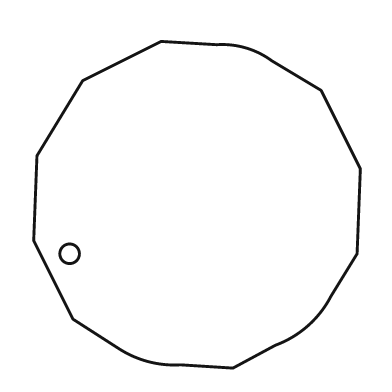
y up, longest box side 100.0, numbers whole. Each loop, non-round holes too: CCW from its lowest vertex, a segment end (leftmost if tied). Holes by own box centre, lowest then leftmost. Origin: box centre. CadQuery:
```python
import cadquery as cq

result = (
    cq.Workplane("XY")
    .moveTo(11.0, -50.0)
    .lineTo(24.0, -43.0)
    .threePointArc((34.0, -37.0), (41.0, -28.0))
    .lineTo(49.0, -15.0)
    .lineTo(50.0, 11.0)
    .lineTo(38.0, 35.0)
    .lineTo(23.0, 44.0)
    .threePointArc((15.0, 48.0), (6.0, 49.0))
    .lineTo(-11.0, 50.0)
    .lineTo(-35.0, 38.0)
    .lineTo(-49.0, 15.0)
    .lineTo(-50.0, -11.0)
    .lineTo(-38.0, -35.0)
    .lineTo(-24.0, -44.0)
    .threePointArc((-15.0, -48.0), (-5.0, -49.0))
    .close()
    .moveTo(-39.0, -15.0)
    .circle(3.0)
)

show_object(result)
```